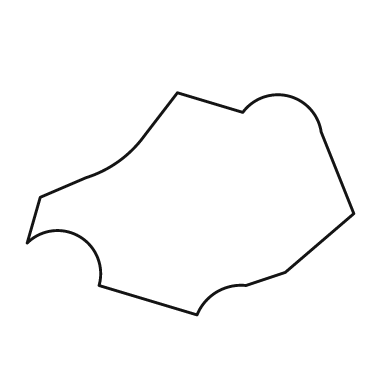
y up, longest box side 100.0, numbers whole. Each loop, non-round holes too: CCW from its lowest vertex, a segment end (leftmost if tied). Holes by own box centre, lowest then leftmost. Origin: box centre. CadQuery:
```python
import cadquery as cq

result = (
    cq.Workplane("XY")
    .moveTo(2.0, -34.0)
    .threePointArc((8.0, -27.0), (17.0, -25.0))
    .lineTo(29.0, -21.0)
    .lineTo(50.0, -3.0)
    .lineTo(40.0, 22.0)
    .threePointArc((30.0, 33.0), (16.0, 28.0))
    .lineTo(-4.0, 34.0)
    .lineTo(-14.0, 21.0)
    .threePointArc((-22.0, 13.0), (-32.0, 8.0))
    .lineTo(-46.0, 2.0)
    .lineTo(-50.0, -12.0)
    .threePointArc((-34.0, -10.0), (-28.0, -25.0))
    .close()
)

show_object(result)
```